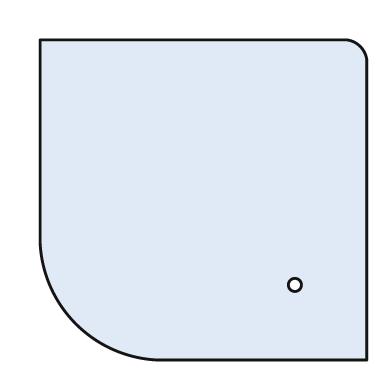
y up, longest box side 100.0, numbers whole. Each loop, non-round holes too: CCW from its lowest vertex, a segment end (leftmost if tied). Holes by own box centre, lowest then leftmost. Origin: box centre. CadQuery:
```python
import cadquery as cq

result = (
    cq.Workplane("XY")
    .moveTo(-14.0, -49.0)
    .lineTo(50.0, -49.0)
    .lineTo(50.0, 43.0)
    .threePointArc((48.0, 47.0), (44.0, 49.0))
    .lineTo(-50.0, 49.0)
    .lineTo(-50.0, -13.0)
    .threePointArc((-39.0, -38.0), (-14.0, -49.0))
    .close()
    .moveTo(28.0, -26.0)
    .circle(2.0)
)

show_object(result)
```